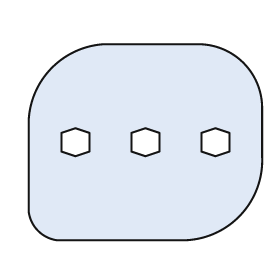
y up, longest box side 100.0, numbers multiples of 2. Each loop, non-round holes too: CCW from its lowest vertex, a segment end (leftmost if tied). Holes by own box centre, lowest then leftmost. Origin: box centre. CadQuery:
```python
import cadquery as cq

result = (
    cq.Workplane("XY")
    .moveTo(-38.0, -42.0)
    .lineTo(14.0, -42.0)
    .threePointArc((40.0, -32.0), (50.0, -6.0))
    .lineTo(50.0, 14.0)
    .threePointArc((42.0, 34.0), (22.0, 42.0))
    .lineTo(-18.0, 42.0)
    .threePointArc((-40.0, 32.0), (-50.0, 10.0))
    .lineTo(-50.0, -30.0)
    .threePointArc((-46.0, -38.0), (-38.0, -42.0))
    .close()
    .moveTo(-30.0, -6.0)
    .lineTo(-24.0, -4.0)
    .lineTo(-24.0, 4.0)
    .lineTo(-30.0, 6.0)
    .lineTo(-36.0, 4.0)
    .lineTo(-36.0, -4.0)
    .close()
    .moveTo(0.0, -6.0)
    .lineTo(6.0, -4.0)
    .lineTo(6.0, 4.0)
    .lineTo(0.0, 6.0)
    .lineTo(-6.0, 4.0)
    .lineTo(-6.0, -4.0)
    .close()
    .moveTo(30.0, -6.0)
    .lineTo(36.0, -4.0)
    .lineTo(36.0, 4.0)
    .lineTo(30.0, 6.0)
    .lineTo(24.0, 4.0)
    .lineTo(24.0, -4.0)
    .close()
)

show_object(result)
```